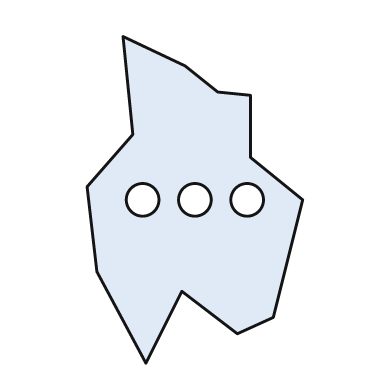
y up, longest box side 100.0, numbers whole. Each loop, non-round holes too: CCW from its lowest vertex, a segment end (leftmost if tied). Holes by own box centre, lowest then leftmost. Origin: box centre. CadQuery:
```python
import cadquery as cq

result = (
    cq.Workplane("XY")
    .moveTo(-15.0, -50.0)
    .lineTo(-4.0, -28.0)
    .lineTo(13.0, -41.0)
    .lineTo(24.0, -36.0)
    .lineTo(33.0, 0.0)
    .lineTo(17.0, 13.0)
    .lineTo(17.0, 32.0)
    .lineTo(7.0, 33.0)
    .lineTo(-3.0, 41.0)
    .lineTo(-22.0, 50.0)
    .lineTo(-19.0, 20.0)
    .lineTo(-33.0, 4.0)
    .lineTo(-30.0, -22.0)
    .close()
    .moveTo(-16.0, 0.0)
    .circle(5.0)
    .moveTo(0.0, 0.0)
    .circle(5.0)
    .moveTo(16.0, 0.0)
    .circle(5.0)
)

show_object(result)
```